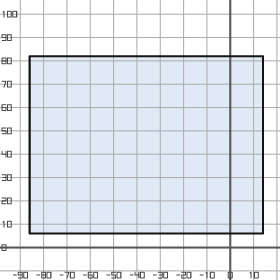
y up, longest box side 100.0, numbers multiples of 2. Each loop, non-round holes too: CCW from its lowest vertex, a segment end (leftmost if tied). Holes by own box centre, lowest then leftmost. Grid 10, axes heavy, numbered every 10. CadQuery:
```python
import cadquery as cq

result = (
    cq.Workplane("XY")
    .moveTo(-86.0, 6.0)
    .lineTo(14.0, 6.0)
    .lineTo(14.0, 82.0)
    .lineTo(-86.0, 82.0)
    .close()
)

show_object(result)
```